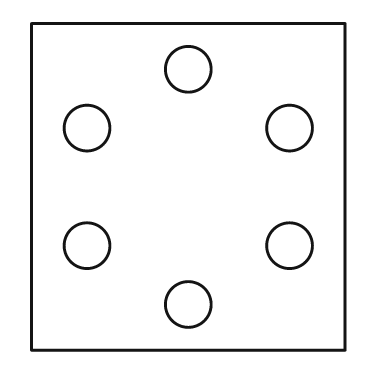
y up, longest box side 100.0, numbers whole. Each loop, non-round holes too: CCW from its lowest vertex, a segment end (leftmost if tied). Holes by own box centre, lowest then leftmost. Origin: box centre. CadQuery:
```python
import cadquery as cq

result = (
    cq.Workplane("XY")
    .moveTo(-48.0, -50.0)
    .lineTo(48.0, -50.0)
    .lineTo(48.0, 50.0)
    .lineTo(-48.0, 50.0)
    .close()
    .moveTo(0.0, -36.0)
    .circle(7.0)
    .moveTo(-31.0, -18.0)
    .circle(7.0)
    .moveTo(31.0, -18.0)
    .circle(7.0)
    .moveTo(-31.0, 18.0)
    .circle(7.0)
    .moveTo(31.0, 18.0)
    .circle(7.0)
    .moveTo(0.0, 36.0)
    .circle(7.0)
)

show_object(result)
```